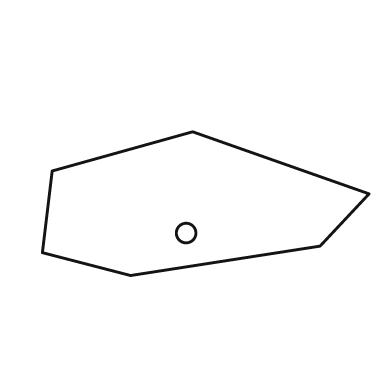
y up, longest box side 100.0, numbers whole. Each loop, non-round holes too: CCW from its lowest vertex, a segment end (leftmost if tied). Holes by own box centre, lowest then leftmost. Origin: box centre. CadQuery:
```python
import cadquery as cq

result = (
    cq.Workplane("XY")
    .moveTo(-23.0, -22.0)
    .lineTo(35.0, -13.0)
    .lineTo(50.0, 3.0)
    .lineTo(-4.0, 22.0)
    .lineTo(-47.0, 10.0)
    .lineTo(-50.0, -15.0)
    .close()
    .moveTo(-6.0, -9.0)
    .circle(3.0)
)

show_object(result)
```